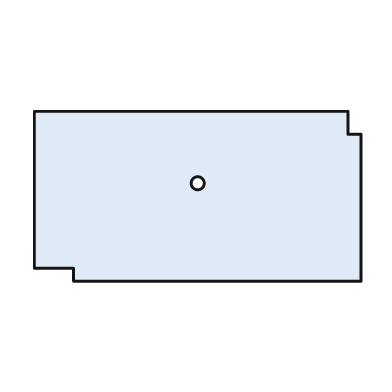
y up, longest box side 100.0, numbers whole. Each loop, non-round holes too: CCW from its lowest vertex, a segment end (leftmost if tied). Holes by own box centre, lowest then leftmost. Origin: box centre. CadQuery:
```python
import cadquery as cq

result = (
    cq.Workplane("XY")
    .moveTo(-38.0, -26.0)
    .lineTo(50.0, -26.0)
    .lineTo(50.0, 19.0)
    .lineTo(46.0, 19.0)
    .lineTo(46.0, 26.0)
    .lineTo(-50.0, 26.0)
    .lineTo(-50.0, -22.0)
    .lineTo(-38.0, -22.0)
    .close()
    .moveTo(0.0, 4.0)
    .circle(2.0)
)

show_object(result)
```